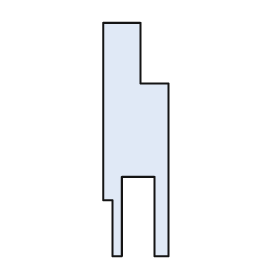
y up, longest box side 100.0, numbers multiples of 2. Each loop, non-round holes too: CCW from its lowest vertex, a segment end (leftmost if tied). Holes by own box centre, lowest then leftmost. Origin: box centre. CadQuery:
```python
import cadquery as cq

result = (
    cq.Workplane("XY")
    .moveTo(-10.0, -50.0)
    .lineTo(-6.0, -50.0)
    .lineTo(-6.0, -16.0)
    .lineTo(8.0, -16.0)
    .lineTo(8.0, -50.0)
    .lineTo(14.0, -50.0)
    .lineTo(14.0, 24.0)
    .lineTo(2.0, 24.0)
    .lineTo(2.0, 50.0)
    .lineTo(-14.0, 50.0)
    .lineTo(-14.0, -26.0)
    .lineTo(-10.0, -26.0)
    .close()
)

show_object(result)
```